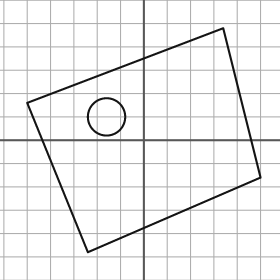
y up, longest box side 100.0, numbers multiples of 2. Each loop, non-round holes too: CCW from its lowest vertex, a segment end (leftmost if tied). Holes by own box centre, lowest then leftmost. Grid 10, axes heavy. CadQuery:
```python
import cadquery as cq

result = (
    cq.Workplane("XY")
    .moveTo(-24.0, -48.0)
    .lineTo(50.0, -16.0)
    .lineTo(34.0, 48.0)
    .lineTo(-50.0, 16.0)
    .close()
    .moveTo(-16.0, 10.0)
    .circle(8.0)
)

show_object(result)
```